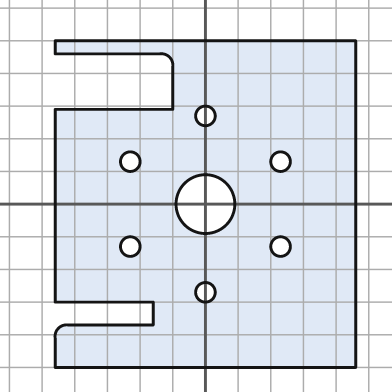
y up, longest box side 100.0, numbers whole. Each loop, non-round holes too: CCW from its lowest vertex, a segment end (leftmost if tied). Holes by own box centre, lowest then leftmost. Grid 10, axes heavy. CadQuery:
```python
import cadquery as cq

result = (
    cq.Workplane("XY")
    .moveTo(-46.0, -50.0)
    .lineTo(46.0, -50.0)
    .lineTo(46.0, 50.0)
    .lineTo(-46.0, 50.0)
    .lineTo(-46.0, 46.0)
    .lineTo(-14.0, 46.0)
    .threePointArc((-11.0, 45.0), (-10.0, 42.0))
    .lineTo(-10.0, 29.0)
    .lineTo(-46.0, 29.0)
    .lineTo(-46.0, -30.0)
    .lineTo(-16.0, -30.0)
    .lineTo(-16.0, -37.0)
    .lineTo(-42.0, -37.0)
    .threePointArc((-45.0, -38.0), (-46.0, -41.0))
    .close()
    .moveTo(0.0, -27.0)
    .circle(3.0)
    .moveTo(-23.0, -13.0)
    .circle(3.0)
    .moveTo(23.0, -13.0)
    .circle(3.0)
    .moveTo(0.0, 0.0)
    .circle(9.0)
    .moveTo(-23.0, 13.0)
    .circle(3.0)
    .moveTo(23.0, 13.0)
    .circle(3.0)
    .moveTo(0.0, 27.0)
    .circle(3.0)
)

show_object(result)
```